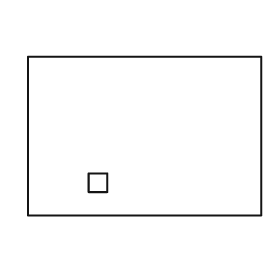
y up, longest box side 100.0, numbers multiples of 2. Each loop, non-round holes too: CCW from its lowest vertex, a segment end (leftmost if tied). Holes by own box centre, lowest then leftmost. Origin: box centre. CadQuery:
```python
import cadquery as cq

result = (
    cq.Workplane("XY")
    .moveTo(-50.0, -34.0)
    .lineTo(50.0, -34.0)
    .lineTo(50.0, 34.0)
    .lineTo(-50.0, 34.0)
    .close()
    .moveTo(-24.0, -24.0)
    .lineTo(-16.0, -24.0)
    .lineTo(-16.0, -16.0)
    .lineTo(-24.0, -16.0)
    .close()
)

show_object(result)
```